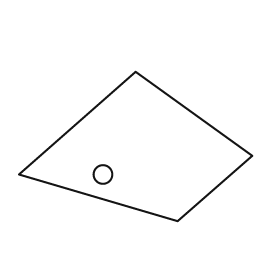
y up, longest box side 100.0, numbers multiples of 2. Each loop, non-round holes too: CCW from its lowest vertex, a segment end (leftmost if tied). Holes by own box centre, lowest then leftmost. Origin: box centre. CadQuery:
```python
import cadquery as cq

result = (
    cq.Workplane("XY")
    .moveTo(18.0, -32.0)
    .lineTo(50.0, -4.0)
    .lineTo(0.0, 32.0)
    .lineTo(-50.0, -12.0)
    .close()
    .moveTo(-14.0, -12.0)
    .circle(4.0)
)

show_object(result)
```